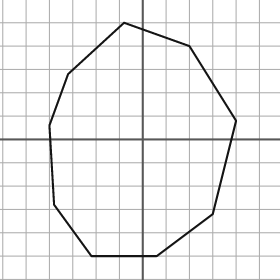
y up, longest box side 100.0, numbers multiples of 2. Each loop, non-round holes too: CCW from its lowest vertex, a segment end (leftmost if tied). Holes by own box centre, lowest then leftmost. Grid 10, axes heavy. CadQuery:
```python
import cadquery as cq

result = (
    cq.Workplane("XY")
    .moveTo(-22.0, -50.0)
    .lineTo(6.0, -50.0)
    .lineTo(30.0, -32.0)
    .lineTo(40.0, 8.0)
    .lineTo(20.0, 40.0)
    .lineTo(-8.0, 50.0)
    .lineTo(-32.0, 28.0)
    .lineTo(-40.0, 6.0)
    .lineTo(-38.0, -28.0)
    .close()
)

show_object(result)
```